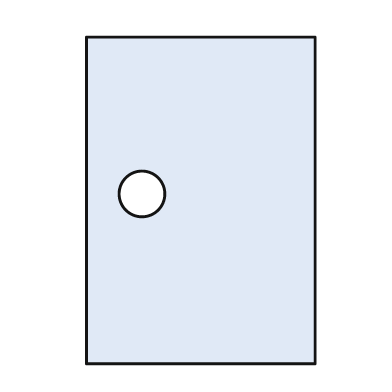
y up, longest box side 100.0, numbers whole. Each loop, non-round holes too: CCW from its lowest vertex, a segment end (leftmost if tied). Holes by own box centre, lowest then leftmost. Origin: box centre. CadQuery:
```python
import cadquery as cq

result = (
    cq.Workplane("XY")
    .moveTo(-35.0, -50.0)
    .lineTo(35.0, -50.0)
    .lineTo(35.0, 50.0)
    .lineTo(-35.0, 50.0)
    .close()
    .moveTo(-18.0, 2.0)
    .circle(7.0)
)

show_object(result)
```